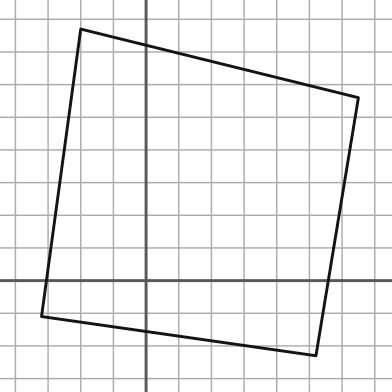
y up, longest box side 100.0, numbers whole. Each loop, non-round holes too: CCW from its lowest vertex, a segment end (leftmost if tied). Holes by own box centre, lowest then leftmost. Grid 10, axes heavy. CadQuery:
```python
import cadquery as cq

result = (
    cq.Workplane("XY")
    .moveTo(52.0, -23.0)
    .lineTo(65.0, 56.0)
    .lineTo(-20.0, 77.0)
    .lineTo(-32.0, -11.0)
    .close()
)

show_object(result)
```